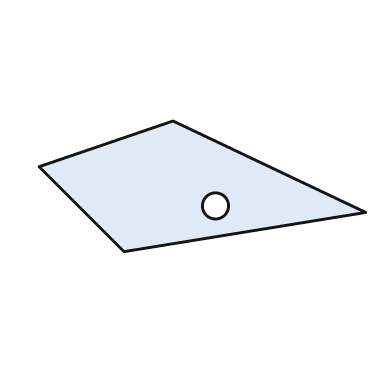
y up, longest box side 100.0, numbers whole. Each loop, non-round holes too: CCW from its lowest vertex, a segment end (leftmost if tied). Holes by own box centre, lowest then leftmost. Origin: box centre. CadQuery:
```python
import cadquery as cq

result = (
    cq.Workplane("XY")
    .moveTo(-24.0, -20.0)
    .lineTo(50.0, -8.0)
    .lineTo(-9.0, 20.0)
    .lineTo(-50.0, 6.0)
    .close()
    .moveTo(4.0, -6.0)
    .circle(4.0)
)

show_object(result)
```